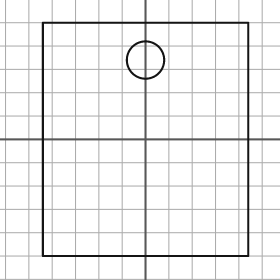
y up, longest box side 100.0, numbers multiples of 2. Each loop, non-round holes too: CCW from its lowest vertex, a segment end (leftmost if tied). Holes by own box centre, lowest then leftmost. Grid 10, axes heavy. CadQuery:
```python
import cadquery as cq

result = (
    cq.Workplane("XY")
    .moveTo(-44.0, -50.0)
    .lineTo(44.0, -50.0)
    .lineTo(44.0, 50.0)
    .lineTo(-44.0, 50.0)
    .close()
    .moveTo(0.0, 34.0)
    .circle(8.0)
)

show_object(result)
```